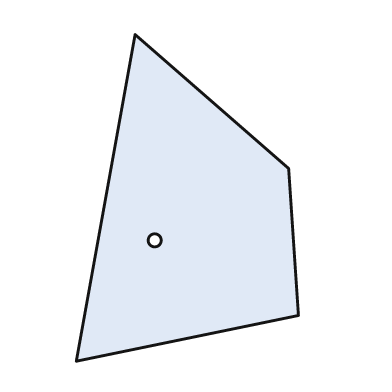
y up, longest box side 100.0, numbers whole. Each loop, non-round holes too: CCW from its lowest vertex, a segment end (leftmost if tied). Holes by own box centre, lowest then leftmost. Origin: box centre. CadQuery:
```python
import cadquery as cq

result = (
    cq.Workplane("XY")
    .moveTo(-34.0, -50.0)
    .lineTo(34.0, -36.0)
    .lineTo(31.0, 9.0)
    .lineTo(-16.0, 50.0)
    .close()
    .moveTo(-10.0, -13.0)
    .circle(2.0)
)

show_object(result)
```